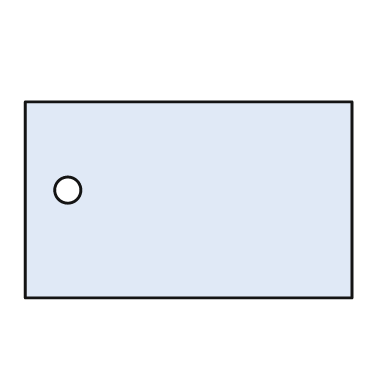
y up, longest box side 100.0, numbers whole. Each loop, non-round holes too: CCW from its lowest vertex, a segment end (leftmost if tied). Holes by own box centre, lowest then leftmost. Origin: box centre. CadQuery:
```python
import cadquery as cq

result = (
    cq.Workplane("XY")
    .moveTo(-50.0, -30.0)
    .lineTo(50.0, -30.0)
    .lineTo(50.0, 30.0)
    .lineTo(-50.0, 30.0)
    .close()
    .moveTo(-37.0, 3.0)
    .circle(4.0)
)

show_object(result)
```